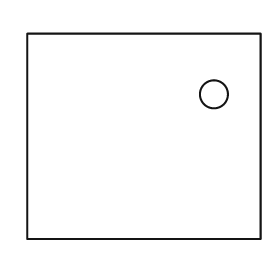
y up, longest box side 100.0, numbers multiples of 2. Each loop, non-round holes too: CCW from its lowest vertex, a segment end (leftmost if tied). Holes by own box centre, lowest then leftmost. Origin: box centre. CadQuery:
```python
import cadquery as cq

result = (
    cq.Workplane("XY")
    .moveTo(-50.0, -44.0)
    .lineTo(50.0, -44.0)
    .lineTo(50.0, 44.0)
    .lineTo(-50.0, 44.0)
    .close()
    .moveTo(30.0, 18.0)
    .circle(6.0)
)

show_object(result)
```